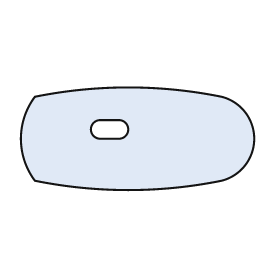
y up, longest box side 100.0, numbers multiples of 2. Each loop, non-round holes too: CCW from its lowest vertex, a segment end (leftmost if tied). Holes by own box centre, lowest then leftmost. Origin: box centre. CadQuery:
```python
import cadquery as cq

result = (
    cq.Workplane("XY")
    .moveTo(-44.0, -18.0)
    .threePointArc((-4.0, -22.0), (36.0, -18.0))
    .threePointArc((50.0, 0.0), (36.0, 18.0))
    .threePointArc((-4.0, 22.0), (-44.0, 18.0))
    .threePointArc((-50.0, 0.0), (-44.0, -18.0))
    .close()
    .moveTo(-16.0, 0.0)
    .lineTo(-8.0, 0.0)
    .threePointArc((-4.0, 4.0), (-8.0, 8.0))
    .lineTo(-16.0, 8.0)
    .threePointArc((-20.0, 4.0), (-16.0, 0.0))
    .close()
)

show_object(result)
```